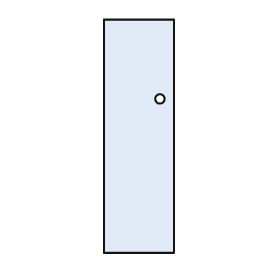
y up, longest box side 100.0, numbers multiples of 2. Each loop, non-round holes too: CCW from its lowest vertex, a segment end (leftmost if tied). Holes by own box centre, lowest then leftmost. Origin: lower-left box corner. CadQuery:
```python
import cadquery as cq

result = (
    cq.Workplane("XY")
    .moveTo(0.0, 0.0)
    .lineTo(30.0, 0.0)
    .lineTo(30.0, 100.0)
    .lineTo(0.0, 100.0)
    .close()
    .moveTo(24.0, 66.0)
    .circle(2.0)
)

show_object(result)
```